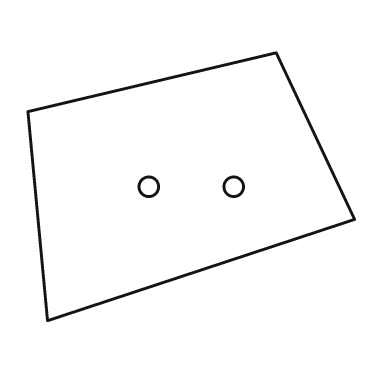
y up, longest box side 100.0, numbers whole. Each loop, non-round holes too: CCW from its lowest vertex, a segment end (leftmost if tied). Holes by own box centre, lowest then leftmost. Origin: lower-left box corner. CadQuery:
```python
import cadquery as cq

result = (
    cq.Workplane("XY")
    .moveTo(6.0, 0.0)
    .lineTo(100.0, 31.0)
    .lineTo(76.0, 82.0)
    .lineTo(0.0, 64.0)
    .close()
    .moveTo(37.0, 41.0)
    .circle(3.0)
    .moveTo(63.0, 41.0)
    .circle(3.0)
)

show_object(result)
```